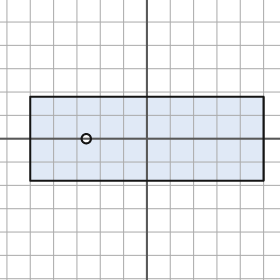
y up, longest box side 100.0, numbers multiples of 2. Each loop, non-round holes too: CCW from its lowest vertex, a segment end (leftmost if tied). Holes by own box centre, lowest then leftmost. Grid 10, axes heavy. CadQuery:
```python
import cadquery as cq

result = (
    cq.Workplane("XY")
    .moveTo(-50.0, -18.0)
    .lineTo(50.0, -18.0)
    .lineTo(50.0, 18.0)
    .lineTo(-50.0, 18.0)
    .close()
    .moveTo(-26.0, 0.0)
    .circle(2.0)
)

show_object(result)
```